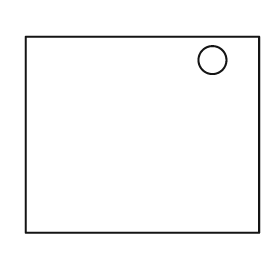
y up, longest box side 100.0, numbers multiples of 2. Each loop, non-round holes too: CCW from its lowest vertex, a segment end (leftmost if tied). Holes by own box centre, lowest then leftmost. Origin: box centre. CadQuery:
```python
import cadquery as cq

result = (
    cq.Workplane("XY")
    .moveTo(-50.0, -42.0)
    .lineTo(50.0, -42.0)
    .lineTo(50.0, 42.0)
    .lineTo(-50.0, 42.0)
    .close()
    .moveTo(30.0, 32.0)
    .circle(6.0)
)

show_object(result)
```